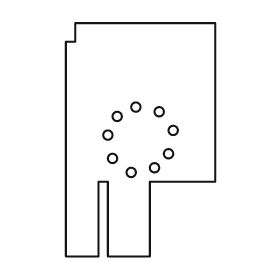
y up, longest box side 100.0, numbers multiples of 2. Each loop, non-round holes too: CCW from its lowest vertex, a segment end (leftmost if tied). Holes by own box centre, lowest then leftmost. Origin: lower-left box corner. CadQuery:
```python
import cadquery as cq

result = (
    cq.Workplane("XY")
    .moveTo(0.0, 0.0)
    .lineTo(14.0, 0.0)
    .lineTo(14.0, 32.0)
    .lineTo(18.0, 32.0)
    .lineTo(18.0, 0.0)
    .lineTo(36.0, 0.0)
    .lineTo(36.0, 32.0)
    .lineTo(64.0, 32.0)
    .lineTo(64.0, 100.0)
    .lineTo(4.0, 100.0)
    .lineTo(4.0, 92.0)
    .lineTo(0.0, 92.0)
    .close()
    .moveTo(28.0, 36.0)
    .circle(2.0)
    .moveTo(38.0, 38.0)
    .circle(2.0)
    .moveTo(20.0, 42.0)
    .circle(2.0)
    .moveTo(44.0, 44.0)
    .circle(2.0)
    .moveTo(18.0, 52.0)
    .circle(2.0)
    .moveTo(46.0, 54.0)
    .circle(2.0)
    .moveTo(22.0, 60.0)
    .circle(2.0)
    .moveTo(40.0, 62.0)
    .circle(2.0)
    .moveTo(30.0, 64.0)
    .circle(2.0)
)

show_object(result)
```